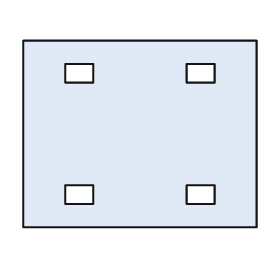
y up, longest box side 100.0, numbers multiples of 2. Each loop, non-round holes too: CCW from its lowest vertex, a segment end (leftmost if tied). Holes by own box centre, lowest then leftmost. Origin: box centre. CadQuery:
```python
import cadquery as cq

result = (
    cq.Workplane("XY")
    .moveTo(-50.0, -40.0)
    .lineTo(50.0, -40.0)
    .lineTo(50.0, 40.0)
    .lineTo(-50.0, 40.0)
    .close()
    .moveTo(-32.0, -30.0)
    .lineTo(-20.0, -30.0)
    .lineTo(-20.0, -22.0)
    .lineTo(-32.0, -22.0)
    .close()
    .moveTo(20.0, -30.0)
    .lineTo(32.0, -30.0)
    .lineTo(32.0, -22.0)
    .lineTo(20.0, -22.0)
    .close()
    .moveTo(-32.0, 22.0)
    .lineTo(-20.0, 22.0)
    .lineTo(-20.0, 30.0)
    .lineTo(-32.0, 30.0)
    .close()
    .moveTo(20.0, 22.0)
    .lineTo(32.0, 22.0)
    .lineTo(32.0, 30.0)
    .lineTo(20.0, 30.0)
    .close()
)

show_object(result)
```